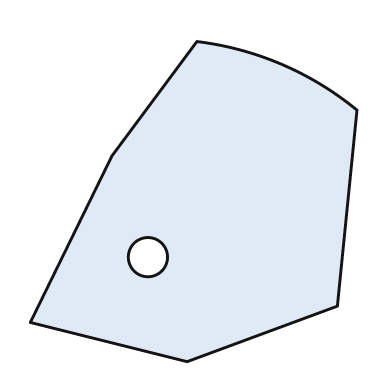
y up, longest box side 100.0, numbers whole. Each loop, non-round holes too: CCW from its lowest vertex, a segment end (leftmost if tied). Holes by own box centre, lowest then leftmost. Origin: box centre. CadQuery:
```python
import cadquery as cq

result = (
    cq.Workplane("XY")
    .moveTo(-2.0, -49.0)
    .lineTo(44.0, -32.0)
    .lineTo(50.0, 28.0)
    .threePointArc((27.0, 42.0), (1.0, 49.0))
    .lineTo(-25.0, 14.0)
    .lineTo(-50.0, -37.0)
    .close()
    .moveTo(-14.0, -17.0)
    .circle(6.0)
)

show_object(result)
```